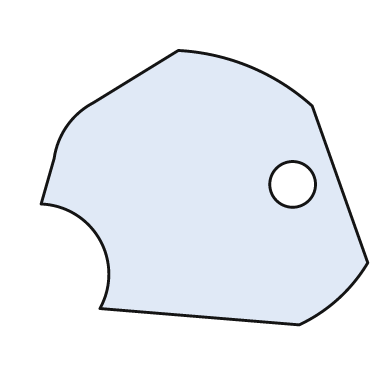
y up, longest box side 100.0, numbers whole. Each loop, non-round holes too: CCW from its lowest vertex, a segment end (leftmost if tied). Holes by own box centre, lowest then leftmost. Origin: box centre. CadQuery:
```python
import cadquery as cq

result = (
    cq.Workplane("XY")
    .moveTo(29.0, -42.0)
    .threePointArc((41.0, -34.0), (50.0, -23.0))
    .lineTo(33.0, 25.0)
    .threePointArc((14.0, 37.0), (-8.0, 42.0))
    .lineTo(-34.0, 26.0)
    .threePointArc((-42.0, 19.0), (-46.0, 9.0))
    .lineTo(-50.0, -5.0)
    .threePointArc((-32.0, -16.0), (-32.0, -37.0))
    .close()
    .moveTo(27.0, 1.0)
    .circle(7.0)
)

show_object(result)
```